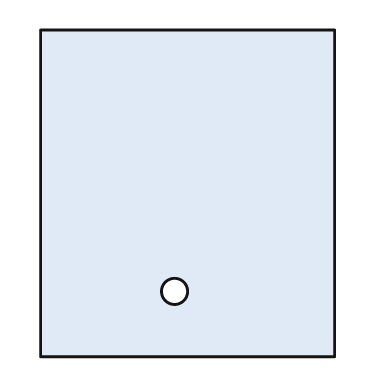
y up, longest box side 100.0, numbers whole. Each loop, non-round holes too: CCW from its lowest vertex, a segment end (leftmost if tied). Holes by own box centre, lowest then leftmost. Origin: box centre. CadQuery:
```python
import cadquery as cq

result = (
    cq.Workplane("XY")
    .moveTo(-45.0, -50.0)
    .lineTo(45.0, -50.0)
    .lineTo(45.0, 50.0)
    .lineTo(-45.0, 50.0)
    .close()
    .moveTo(-4.0, -30.0)
    .circle(4.0)
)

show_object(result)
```